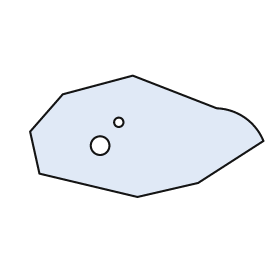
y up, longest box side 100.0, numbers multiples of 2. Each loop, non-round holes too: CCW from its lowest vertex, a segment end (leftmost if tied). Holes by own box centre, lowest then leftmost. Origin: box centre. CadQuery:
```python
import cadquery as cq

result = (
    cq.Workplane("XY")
    .moveTo(-4.0, -26.0)
    .lineTo(22.0, -20.0)
    .lineTo(50.0, -2.0)
    .threePointArc((42.0, 8.0), (30.0, 12.0))
    .lineTo(-6.0, 26.0)
    .lineTo(-36.0, 18.0)
    .lineTo(-50.0, 2.0)
    .lineTo(-46.0, -16.0)
    .close()
    .moveTo(-20.0, -4.0)
    .circle(4.0)
    .moveTo(-12.0, 6.0)
    .circle(2.0)
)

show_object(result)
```